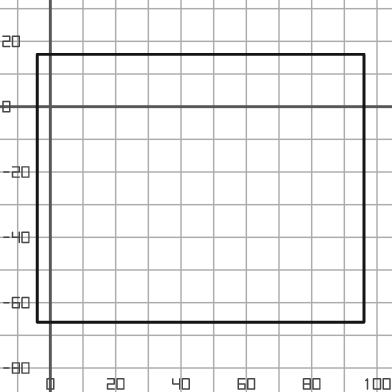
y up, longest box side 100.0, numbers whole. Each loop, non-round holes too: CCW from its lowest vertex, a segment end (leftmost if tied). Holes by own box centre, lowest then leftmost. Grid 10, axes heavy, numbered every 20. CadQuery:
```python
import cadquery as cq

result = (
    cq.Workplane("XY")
    .moveTo(-4.0, -66.0)
    .lineTo(96.0, -66.0)
    .lineTo(96.0, 16.0)
    .lineTo(-4.0, 16.0)
    .close()
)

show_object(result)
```